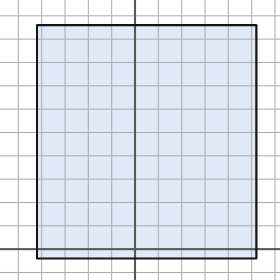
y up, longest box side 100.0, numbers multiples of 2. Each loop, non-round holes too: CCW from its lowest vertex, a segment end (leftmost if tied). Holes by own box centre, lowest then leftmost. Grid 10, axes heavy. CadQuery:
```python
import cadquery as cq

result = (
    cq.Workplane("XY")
    .moveTo(-42.0, -4.0)
    .lineTo(52.0, -4.0)
    .lineTo(52.0, 96.0)
    .lineTo(-42.0, 96.0)
    .close()
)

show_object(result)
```